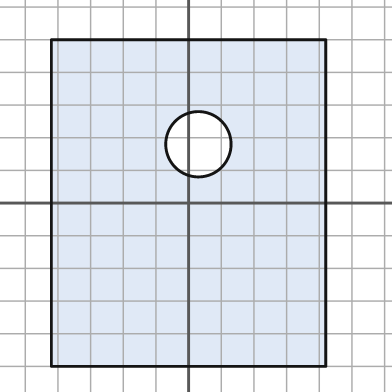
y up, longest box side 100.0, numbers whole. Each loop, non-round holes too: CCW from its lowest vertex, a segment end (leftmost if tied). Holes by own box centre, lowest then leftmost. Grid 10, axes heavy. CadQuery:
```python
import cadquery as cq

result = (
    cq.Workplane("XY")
    .moveTo(-42.0, -50.0)
    .lineTo(42.0, -50.0)
    .lineTo(42.0, 50.0)
    .lineTo(-42.0, 50.0)
    .close()
    .moveTo(3.0, 18.0)
    .circle(10.0)
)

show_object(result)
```